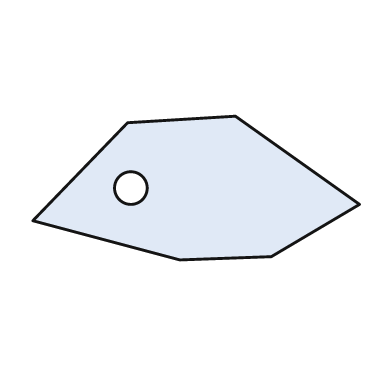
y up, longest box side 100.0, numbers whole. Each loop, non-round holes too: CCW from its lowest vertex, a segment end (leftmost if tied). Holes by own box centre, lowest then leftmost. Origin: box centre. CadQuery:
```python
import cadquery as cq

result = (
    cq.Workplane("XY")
    .moveTo(-5.0, -22.0)
    .lineTo(23.0, -21.0)
    .lineTo(50.0, -5.0)
    .lineTo(12.0, 22.0)
    .lineTo(-21.0, 20.0)
    .lineTo(-50.0, -10.0)
    .close()
    .moveTo(-20.0, 0.0)
    .circle(5.0)
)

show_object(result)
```